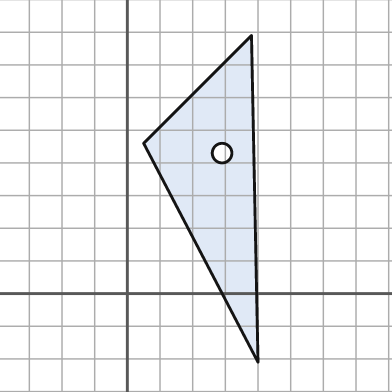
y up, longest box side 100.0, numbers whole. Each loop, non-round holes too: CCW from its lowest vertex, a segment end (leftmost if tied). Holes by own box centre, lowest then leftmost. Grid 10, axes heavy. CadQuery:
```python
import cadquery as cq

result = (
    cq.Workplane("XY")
    .moveTo(40.0, -21.0)
    .lineTo(38.0, 79.0)
    .lineTo(5.0, 46.0)
    .close()
    .moveTo(29.0, 43.0)
    .circle(3.0)
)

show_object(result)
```